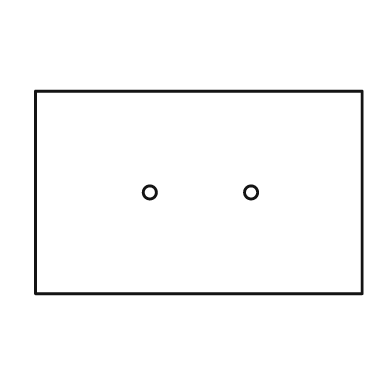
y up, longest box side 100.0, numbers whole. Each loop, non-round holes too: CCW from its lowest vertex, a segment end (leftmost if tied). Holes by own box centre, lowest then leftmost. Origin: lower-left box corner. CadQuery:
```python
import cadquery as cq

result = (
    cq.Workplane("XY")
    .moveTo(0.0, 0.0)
    .lineTo(100.0, 0.0)
    .lineTo(100.0, 62.0)
    .lineTo(0.0, 62.0)
    .close()
    .moveTo(35.0, 31.0)
    .circle(2.0)
    .moveTo(66.0, 31.0)
    .circle(2.0)
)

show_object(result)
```